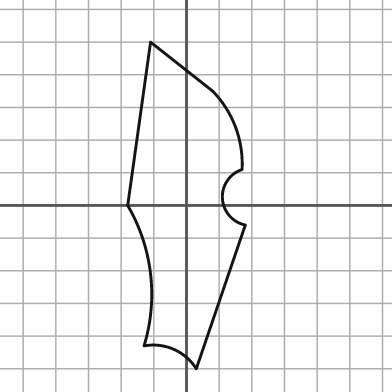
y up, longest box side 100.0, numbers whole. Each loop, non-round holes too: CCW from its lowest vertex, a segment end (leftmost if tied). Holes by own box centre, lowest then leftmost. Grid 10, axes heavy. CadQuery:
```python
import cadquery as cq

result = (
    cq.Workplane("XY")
    .moveTo(3.0, -50.0)
    .lineTo(18.0, -6.0)
    .threePointArc((11.0, 2.0), (17.0, 11.0))
    .threePointArc((15.0, 24.0), (8.0, 35.0))
    .lineTo(-11.0, 50.0)
    .lineTo(-18.0, 0.0)
    .threePointArc((-11.0, -21.0), (-13.0, -43.0))
    .threePointArc((-4.0, -44.0), (3.0, -50.0))
    .close()
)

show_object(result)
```